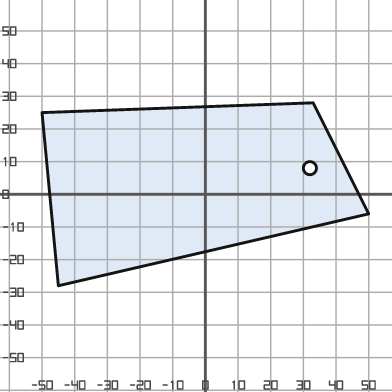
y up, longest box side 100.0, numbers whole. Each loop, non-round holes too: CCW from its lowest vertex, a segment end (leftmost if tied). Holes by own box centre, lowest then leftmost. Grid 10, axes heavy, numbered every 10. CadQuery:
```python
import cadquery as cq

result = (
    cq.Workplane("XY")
    .moveTo(-45.0, -28.0)
    .lineTo(50.0, -6.0)
    .lineTo(33.0, 28.0)
    .lineTo(-50.0, 25.0)
    .close()
    .moveTo(32.0, 8.0)
    .circle(2.0)
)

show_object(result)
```